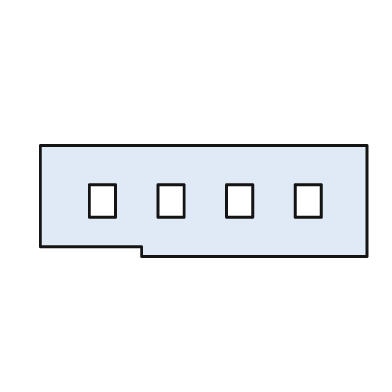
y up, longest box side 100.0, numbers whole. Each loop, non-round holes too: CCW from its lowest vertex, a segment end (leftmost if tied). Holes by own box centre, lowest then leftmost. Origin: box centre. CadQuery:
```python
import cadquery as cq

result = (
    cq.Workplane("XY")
    .moveTo(-19.0, -17.0)
    .lineTo(50.0, -17.0)
    .lineTo(50.0, 17.0)
    .lineTo(-50.0, 17.0)
    .lineTo(-50.0, -14.0)
    .lineTo(-19.0, -14.0)
    .close()
    .moveTo(-35.0, -5.0)
    .lineTo(-27.0, -5.0)
    .lineTo(-27.0, 5.0)
    .lineTo(-35.0, 5.0)
    .close()
    .moveTo(-14.0, -5.0)
    .lineTo(-6.0, -5.0)
    .lineTo(-6.0, 5.0)
    .lineTo(-14.0, 5.0)
    .close()
    .moveTo(7.0, -5.0)
    .lineTo(15.0, -5.0)
    .lineTo(15.0, 5.0)
    .lineTo(7.0, 5.0)
    .close()
    .moveTo(28.0, -5.0)
    .lineTo(36.0, -5.0)
    .lineTo(36.0, 5.0)
    .lineTo(28.0, 5.0)
    .close()
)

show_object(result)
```